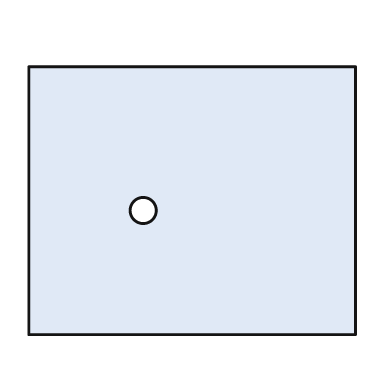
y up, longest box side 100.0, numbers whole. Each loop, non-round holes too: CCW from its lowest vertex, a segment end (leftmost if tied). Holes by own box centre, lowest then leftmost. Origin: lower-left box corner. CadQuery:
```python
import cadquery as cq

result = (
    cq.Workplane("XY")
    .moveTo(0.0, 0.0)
    .lineTo(100.0, 0.0)
    .lineTo(100.0, 82.0)
    .lineTo(0.0, 82.0)
    .close()
    .moveTo(35.0, 38.0)
    .circle(4.0)
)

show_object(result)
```